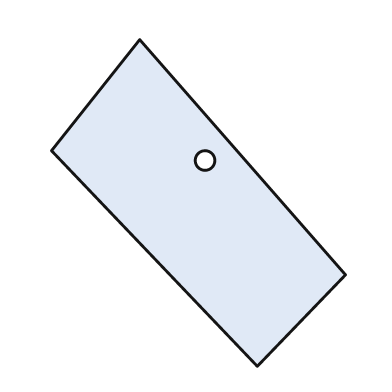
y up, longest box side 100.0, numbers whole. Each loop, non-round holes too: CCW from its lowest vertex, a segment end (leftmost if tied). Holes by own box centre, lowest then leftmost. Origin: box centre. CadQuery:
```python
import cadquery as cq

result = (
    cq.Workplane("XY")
    .moveTo(18.0, -50.0)
    .lineTo(45.0, -22.0)
    .lineTo(-18.0, 50.0)
    .lineTo(-45.0, 16.0)
    .close()
    .moveTo(2.0, 13.0)
    .circle(3.0)
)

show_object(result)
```